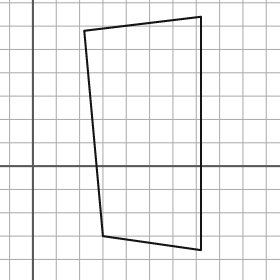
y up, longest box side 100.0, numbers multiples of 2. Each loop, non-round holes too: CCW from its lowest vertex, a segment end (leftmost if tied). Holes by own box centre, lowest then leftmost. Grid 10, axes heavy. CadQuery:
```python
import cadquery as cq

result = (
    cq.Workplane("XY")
    .moveTo(72.0, -36.0)
    .lineTo(72.0, 64.0)
    .lineTo(22.0, 58.0)
    .lineTo(30.0, -30.0)
    .close()
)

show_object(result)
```